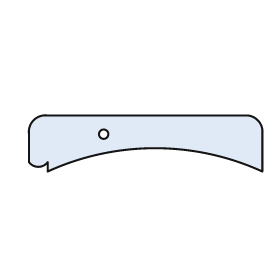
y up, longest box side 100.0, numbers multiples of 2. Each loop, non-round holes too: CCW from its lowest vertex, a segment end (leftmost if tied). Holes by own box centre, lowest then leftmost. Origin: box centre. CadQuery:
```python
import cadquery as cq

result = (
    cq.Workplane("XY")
    .moveTo(-42.0, -12.0)
    .threePointArc((4.0, -2.0), (50.0, -12.0))
    .lineTo(50.0, 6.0)
    .threePointArc((48.0, 10.0), (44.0, 12.0))
    .lineTo(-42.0, 12.0)
    .threePointArc((-48.0, 10.0), (-50.0, 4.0))
    .lineTo(-50.0, -8.0)
    .threePointArc((-46.0, -10.0), (-42.0, -8.0))
    .close()
    .moveTo(-18.0, 4.0)
    .circle(2.0)
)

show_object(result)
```